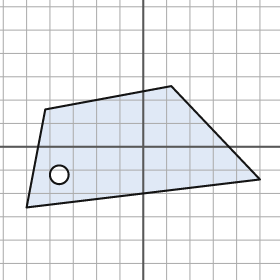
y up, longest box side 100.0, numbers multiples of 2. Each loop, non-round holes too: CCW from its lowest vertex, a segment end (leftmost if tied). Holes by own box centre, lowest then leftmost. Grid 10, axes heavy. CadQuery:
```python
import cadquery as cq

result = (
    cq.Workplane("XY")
    .moveTo(-50.0, -26.0)
    .lineTo(50.0, -14.0)
    .lineTo(12.0, 26.0)
    .lineTo(-42.0, 16.0)
    .close()
    .moveTo(-36.0, -12.0)
    .circle(4.0)
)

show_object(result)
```